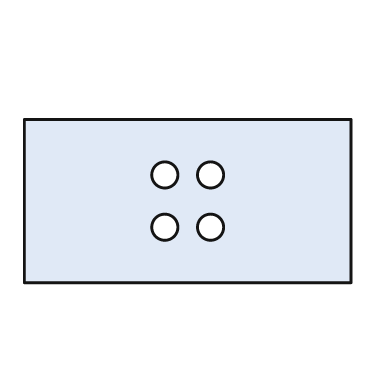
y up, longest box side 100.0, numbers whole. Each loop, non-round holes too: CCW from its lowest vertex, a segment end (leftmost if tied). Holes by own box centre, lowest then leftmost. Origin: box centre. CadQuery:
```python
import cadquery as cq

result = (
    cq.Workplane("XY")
    .moveTo(-50.0, -25.0)
    .lineTo(50.0, -25.0)
    .lineTo(50.0, 25.0)
    .lineTo(-50.0, 25.0)
    .close()
    .moveTo(-7.0, -8.0)
    .circle(4.0)
    .moveTo(7.0, -8.0)
    .circle(4.0)
    .moveTo(-7.0, 8.0)
    .circle(4.0)
    .moveTo(7.0, 8.0)
    .circle(4.0)
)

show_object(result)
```